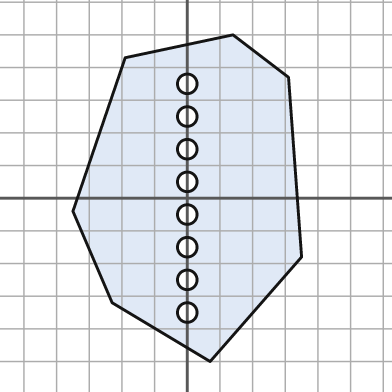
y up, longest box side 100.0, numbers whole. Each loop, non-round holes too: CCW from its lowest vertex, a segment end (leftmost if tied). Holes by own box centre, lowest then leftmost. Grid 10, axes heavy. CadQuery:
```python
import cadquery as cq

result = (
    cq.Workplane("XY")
    .moveTo(7.0, -50.0)
    .lineTo(35.0, -18.0)
    .lineTo(31.0, 37.0)
    .lineTo(14.0, 50.0)
    .lineTo(-19.0, 43.0)
    .lineTo(-35.0, -4.0)
    .lineTo(-23.0, -32.0)
    .close()
    .moveTo(0.0, -35.0)
    .circle(3.0)
    .moveTo(0.0, -25.0)
    .circle(3.0)
    .moveTo(0.0, -15.0)
    .circle(3.0)
    .moveTo(0.0, -5.0)
    .circle(3.0)
    .moveTo(0.0, 5.0)
    .circle(3.0)
    .moveTo(0.0, 15.0)
    .circle(3.0)
    .moveTo(0.0, 25.0)
    .circle(3.0)
    .moveTo(0.0, 35.0)
    .circle(3.0)
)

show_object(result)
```